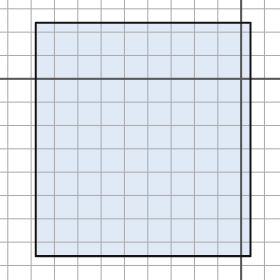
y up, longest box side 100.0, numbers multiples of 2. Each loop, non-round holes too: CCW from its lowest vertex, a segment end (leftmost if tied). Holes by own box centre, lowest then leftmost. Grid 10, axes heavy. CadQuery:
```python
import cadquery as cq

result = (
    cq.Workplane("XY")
    .moveTo(-88.0, -76.0)
    .lineTo(4.0, -76.0)
    .lineTo(4.0, 24.0)
    .lineTo(-88.0, 24.0)
    .close()
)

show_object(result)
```